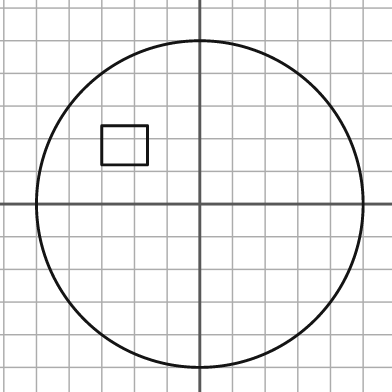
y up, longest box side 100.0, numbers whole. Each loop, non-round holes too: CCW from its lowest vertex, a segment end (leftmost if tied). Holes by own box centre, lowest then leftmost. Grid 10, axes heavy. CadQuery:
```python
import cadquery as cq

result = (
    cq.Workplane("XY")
    .moveTo(0.0, 0.0)
    .circle(50.0)
    .moveTo(-30.0, 12.0)
    .lineTo(-16.0, 12.0)
    .lineTo(-16.0, 24.0)
    .lineTo(-30.0, 24.0)
    .close()
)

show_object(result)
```